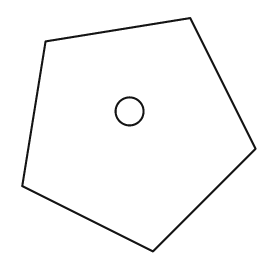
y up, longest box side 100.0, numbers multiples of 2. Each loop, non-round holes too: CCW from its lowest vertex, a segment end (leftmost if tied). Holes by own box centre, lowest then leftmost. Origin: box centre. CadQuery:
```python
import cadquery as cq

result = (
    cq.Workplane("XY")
    .moveTo(6.0, -50.0)
    .lineTo(50.0, -6.0)
    .lineTo(22.0, 50.0)
    .lineTo(-40.0, 40.0)
    .lineTo(-50.0, -22.0)
    .close()
    .moveTo(-4.0, 10.0)
    .circle(6.0)
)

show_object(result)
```